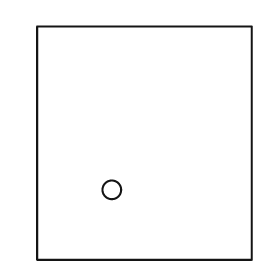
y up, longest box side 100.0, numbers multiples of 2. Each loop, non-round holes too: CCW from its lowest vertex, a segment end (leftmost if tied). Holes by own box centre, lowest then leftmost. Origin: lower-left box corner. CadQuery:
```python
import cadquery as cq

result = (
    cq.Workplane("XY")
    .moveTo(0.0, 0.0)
    .lineTo(92.0, 0.0)
    .lineTo(92.0, 100.0)
    .lineTo(0.0, 100.0)
    .close()
    .moveTo(32.0, 30.0)
    .circle(4.0)
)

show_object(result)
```